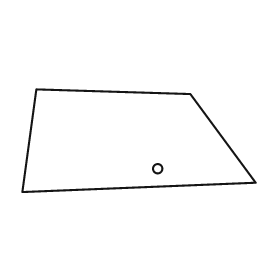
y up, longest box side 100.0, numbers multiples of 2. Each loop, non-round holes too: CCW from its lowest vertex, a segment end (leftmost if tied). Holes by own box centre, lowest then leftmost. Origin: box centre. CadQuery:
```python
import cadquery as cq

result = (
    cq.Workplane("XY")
    .moveTo(-50.0, -22.0)
    .lineTo(50.0, -18.0)
    .lineTo(22.0, 20.0)
    .lineTo(-44.0, 22.0)
    .close()
    .moveTo(8.0, -12.0)
    .circle(2.0)
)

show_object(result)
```